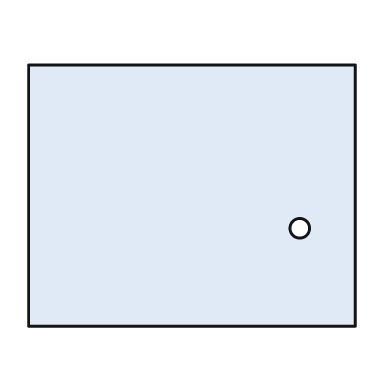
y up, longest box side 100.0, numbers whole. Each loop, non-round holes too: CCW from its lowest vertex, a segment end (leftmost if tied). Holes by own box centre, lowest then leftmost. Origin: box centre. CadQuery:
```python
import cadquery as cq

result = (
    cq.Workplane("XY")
    .moveTo(-50.0, -40.0)
    .lineTo(50.0, -40.0)
    .lineTo(50.0, 40.0)
    .lineTo(-50.0, 40.0)
    .close()
    .moveTo(33.0, -10.0)
    .circle(3.0)
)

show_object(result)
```